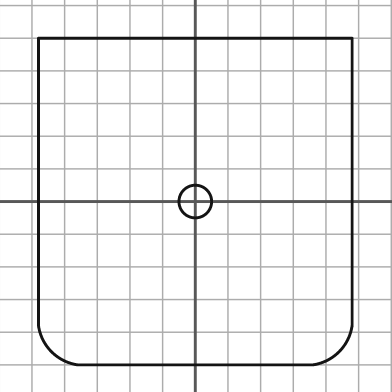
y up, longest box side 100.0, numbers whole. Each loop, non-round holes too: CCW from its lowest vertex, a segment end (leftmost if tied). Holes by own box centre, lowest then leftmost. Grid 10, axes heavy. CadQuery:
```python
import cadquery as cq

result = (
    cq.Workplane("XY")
    .moveTo(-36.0, -50.0)
    .lineTo(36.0, -50.0)
    .threePointArc((44.0, -46.0), (48.0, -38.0))
    .lineTo(48.0, 50.0)
    .lineTo(-48.0, 50.0)
    .lineTo(-48.0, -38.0)
    .threePointArc((-44.0, -46.0), (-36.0, -50.0))
    .close()
    .moveTo(0.0, 0.0)
    .circle(5.0)
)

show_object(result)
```